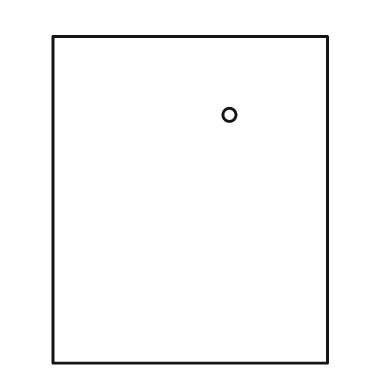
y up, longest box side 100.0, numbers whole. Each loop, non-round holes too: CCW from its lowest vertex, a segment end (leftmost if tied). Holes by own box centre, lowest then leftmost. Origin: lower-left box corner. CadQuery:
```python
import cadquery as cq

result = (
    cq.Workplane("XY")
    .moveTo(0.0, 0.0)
    .lineTo(84.0, 0.0)
    .lineTo(84.0, 100.0)
    .lineTo(0.0, 100.0)
    .close()
    .moveTo(54.0, 76.0)
    .circle(2.0)
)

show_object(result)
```